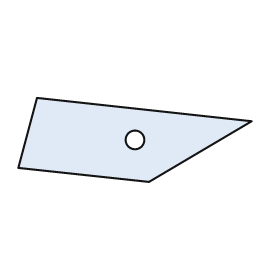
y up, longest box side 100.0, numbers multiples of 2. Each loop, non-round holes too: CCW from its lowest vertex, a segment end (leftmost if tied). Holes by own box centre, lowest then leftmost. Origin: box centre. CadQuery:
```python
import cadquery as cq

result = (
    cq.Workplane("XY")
    .moveTo(6.0, -18.0)
    .lineTo(50.0, 8.0)
    .lineTo(-42.0, 18.0)
    .lineTo(-50.0, -12.0)
    .close()
    .moveTo(0.0, 0.0)
    .circle(4.0)
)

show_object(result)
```